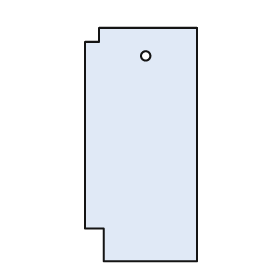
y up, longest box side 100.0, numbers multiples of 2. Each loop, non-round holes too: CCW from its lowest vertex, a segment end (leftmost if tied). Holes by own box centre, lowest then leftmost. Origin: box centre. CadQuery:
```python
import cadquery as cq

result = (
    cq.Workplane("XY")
    .moveTo(-16.0, -50.0)
    .lineTo(24.0, -50.0)
    .lineTo(24.0, 50.0)
    .lineTo(-18.0, 50.0)
    .lineTo(-18.0, 44.0)
    .lineTo(-24.0, 44.0)
    .lineTo(-24.0, -36.0)
    .lineTo(-16.0, -36.0)
    .close()
    .moveTo(2.0, 38.0)
    .circle(2.0)
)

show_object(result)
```